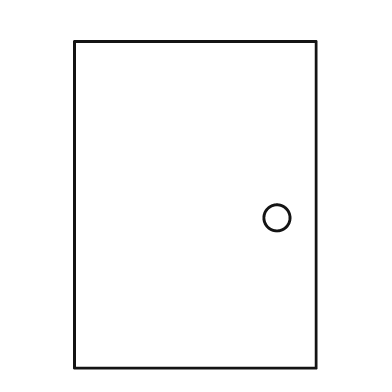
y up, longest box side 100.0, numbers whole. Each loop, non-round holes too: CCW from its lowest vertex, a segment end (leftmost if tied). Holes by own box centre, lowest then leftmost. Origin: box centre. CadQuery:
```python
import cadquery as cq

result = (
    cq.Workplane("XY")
    .moveTo(-37.0, -50.0)
    .lineTo(37.0, -50.0)
    .lineTo(37.0, 50.0)
    .lineTo(-37.0, 50.0)
    .close()
    .moveTo(25.0, -4.0)
    .circle(4.0)
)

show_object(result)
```